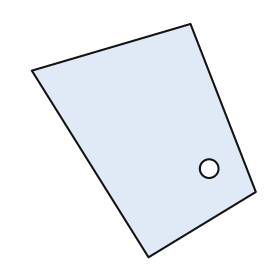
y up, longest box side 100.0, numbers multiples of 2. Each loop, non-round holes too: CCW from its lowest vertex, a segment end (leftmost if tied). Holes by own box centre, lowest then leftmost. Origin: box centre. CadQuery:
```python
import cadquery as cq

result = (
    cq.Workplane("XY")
    .moveTo(2.0, -50.0)
    .lineTo(48.0, -22.0)
    .lineTo(20.0, 50.0)
    .lineTo(-48.0, 30.0)
    .close()
    .moveTo(28.0, -12.0)
    .circle(4.0)
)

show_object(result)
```